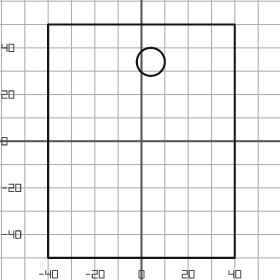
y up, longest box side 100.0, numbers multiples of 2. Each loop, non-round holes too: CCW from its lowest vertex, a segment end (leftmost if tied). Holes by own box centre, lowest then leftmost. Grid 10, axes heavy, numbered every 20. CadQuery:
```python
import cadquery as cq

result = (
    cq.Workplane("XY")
    .moveTo(-40.0, -50.0)
    .lineTo(40.0, -50.0)
    .lineTo(40.0, 50.0)
    .lineTo(-40.0, 50.0)
    .close()
    .moveTo(4.0, 34.0)
    .circle(6.0)
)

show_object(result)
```